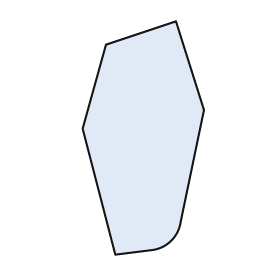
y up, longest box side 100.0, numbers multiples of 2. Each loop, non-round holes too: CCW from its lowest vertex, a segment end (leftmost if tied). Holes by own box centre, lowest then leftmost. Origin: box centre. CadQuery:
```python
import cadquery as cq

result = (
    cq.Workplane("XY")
    .moveTo(-12.0, -50.0)
    .lineTo(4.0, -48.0)
    .threePointArc((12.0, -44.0), (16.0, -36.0))
    .lineTo(26.0, 12.0)
    .lineTo(14.0, 50.0)
    .lineTo(-16.0, 40.0)
    .lineTo(-26.0, 4.0)
    .close()
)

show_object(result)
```